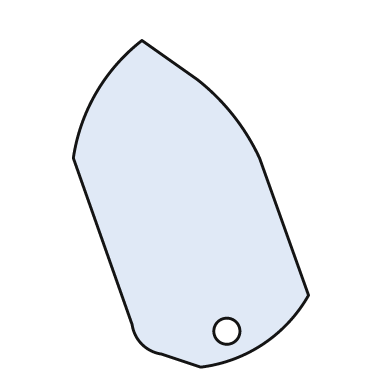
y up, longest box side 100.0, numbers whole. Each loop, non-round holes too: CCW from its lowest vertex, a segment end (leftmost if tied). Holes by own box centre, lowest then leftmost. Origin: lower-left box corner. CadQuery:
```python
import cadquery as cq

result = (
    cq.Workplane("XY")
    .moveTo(39.0, 0.0)
    .threePointArc((58.0, 7.0), (72.0, 22.0))
    .lineTo(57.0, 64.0)
    .threePointArc((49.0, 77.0), (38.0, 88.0))
    .lineTo(21.0, 100.0)
    .threePointArc((7.0, 84.0), (0.0, 64.0))
    .lineTo(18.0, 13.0)
    .threePointArc((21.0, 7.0), (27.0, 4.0))
    .close()
    .moveTo(47.0, 11.0)
    .circle(4.0)
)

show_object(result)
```